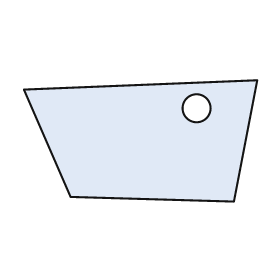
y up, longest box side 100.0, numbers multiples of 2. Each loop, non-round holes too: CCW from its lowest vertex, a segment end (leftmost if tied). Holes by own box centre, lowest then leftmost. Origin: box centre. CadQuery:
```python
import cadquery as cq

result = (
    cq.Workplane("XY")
    .moveTo(40.0, -26.0)
    .lineTo(50.0, 26.0)
    .lineTo(-50.0, 22.0)
    .lineTo(-30.0, -24.0)
    .close()
    .moveTo(24.0, 14.0)
    .circle(6.0)
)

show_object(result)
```